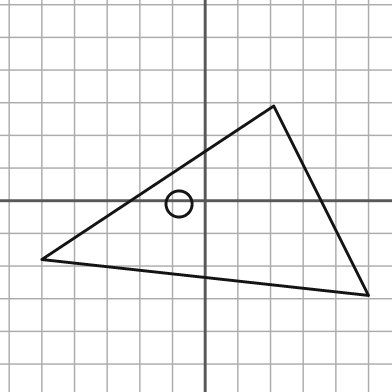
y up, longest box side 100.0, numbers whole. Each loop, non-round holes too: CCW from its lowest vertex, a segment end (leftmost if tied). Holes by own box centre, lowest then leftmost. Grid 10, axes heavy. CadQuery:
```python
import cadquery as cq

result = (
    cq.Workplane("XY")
    .moveTo(50.0, -29.0)
    .lineTo(21.0, 29.0)
    .lineTo(-50.0, -18.0)
    .close()
    .moveTo(-8.0, -1.0)
    .circle(4.0)
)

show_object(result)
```